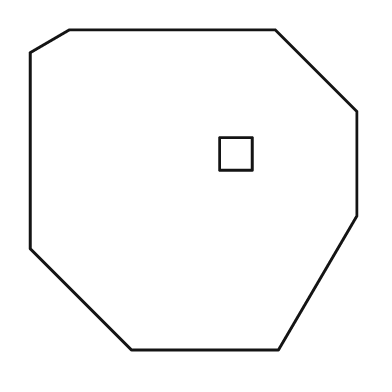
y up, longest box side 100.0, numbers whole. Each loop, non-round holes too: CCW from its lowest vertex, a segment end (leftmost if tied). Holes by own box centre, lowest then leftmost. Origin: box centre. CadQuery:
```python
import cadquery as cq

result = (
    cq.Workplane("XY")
    .moveTo(-19.0, -49.0)
    .lineTo(26.0, -49.0)
    .lineTo(50.0, -8.0)
    .lineTo(50.0, 24.0)
    .lineTo(25.0, 49.0)
    .lineTo(-38.0, 49.0)
    .lineTo(-50.0, 42.0)
    .lineTo(-50.0, -18.0)
    .close()
    .moveTo(8.0, 6.0)
    .lineTo(18.0, 6.0)
    .lineTo(18.0, 16.0)
    .lineTo(8.0, 16.0)
    .close()
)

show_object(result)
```